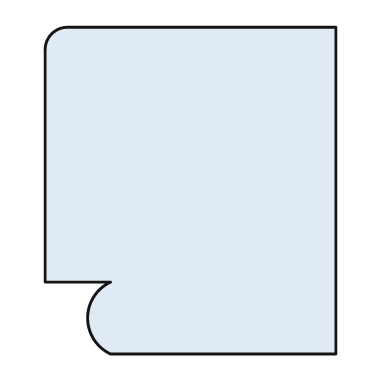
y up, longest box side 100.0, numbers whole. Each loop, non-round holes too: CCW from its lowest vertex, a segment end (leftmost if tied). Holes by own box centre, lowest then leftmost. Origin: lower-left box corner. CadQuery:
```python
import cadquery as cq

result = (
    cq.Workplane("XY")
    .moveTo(20.0, 0.0)
    .lineTo(89.0, 0.0)
    .lineTo(89.0, 100.0)
    .lineTo(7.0, 100.0)
    .threePointArc((2.0, 98.0), (0.0, 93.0))
    .lineTo(0.0, 22.0)
    .lineTo(20.0, 22.0)
    .threePointArc((13.0, 11.0), (20.0, 0.0))
    .close()
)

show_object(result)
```